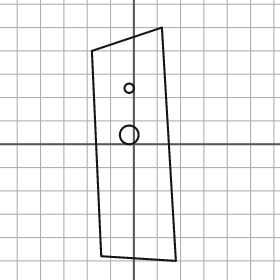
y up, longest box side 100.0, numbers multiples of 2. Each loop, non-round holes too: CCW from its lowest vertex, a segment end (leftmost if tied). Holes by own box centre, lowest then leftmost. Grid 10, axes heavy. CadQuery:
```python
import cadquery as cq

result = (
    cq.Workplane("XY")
    .moveTo(18.0, -50.0)
    .lineTo(12.0, 50.0)
    .lineTo(-18.0, 40.0)
    .lineTo(-14.0, -48.0)
    .close()
    .moveTo(-2.0, 4.0)
    .circle(4.0)
    .moveTo(-2.0, 24.0)
    .circle(2.0)
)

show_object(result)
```